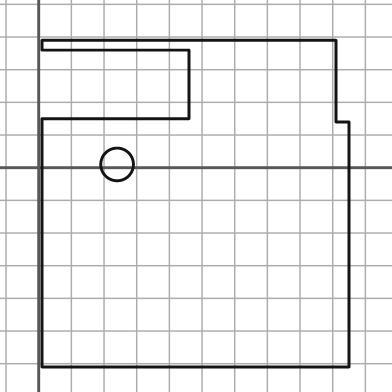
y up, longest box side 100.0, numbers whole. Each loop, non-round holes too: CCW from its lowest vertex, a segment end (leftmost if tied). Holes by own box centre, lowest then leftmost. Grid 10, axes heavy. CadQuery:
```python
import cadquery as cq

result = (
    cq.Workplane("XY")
    .moveTo(1.0, -61.0)
    .lineTo(95.0, -61.0)
    .lineTo(95.0, 14.0)
    .lineTo(91.0, 14.0)
    .lineTo(91.0, 39.0)
    .lineTo(1.0, 39.0)
    .lineTo(1.0, 36.0)
    .lineTo(46.0, 36.0)
    .lineTo(46.0, 15.0)
    .lineTo(1.0, 15.0)
    .close()
    .moveTo(24.0, 1.0)
    .circle(5.0)
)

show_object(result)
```